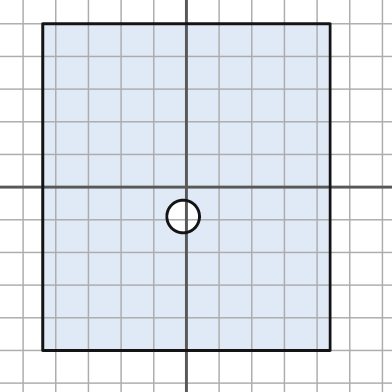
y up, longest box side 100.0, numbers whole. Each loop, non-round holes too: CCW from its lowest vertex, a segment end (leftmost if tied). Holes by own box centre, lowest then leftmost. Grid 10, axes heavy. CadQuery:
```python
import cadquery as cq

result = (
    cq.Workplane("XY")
    .moveTo(-44.0, -50.0)
    .lineTo(44.0, -50.0)
    .lineTo(44.0, 50.0)
    .lineTo(-44.0, 50.0)
    .close()
    .moveTo(-1.0, -9.0)
    .circle(5.0)
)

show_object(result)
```